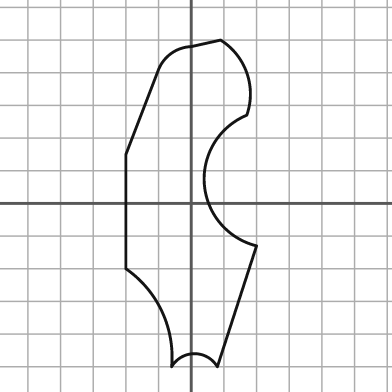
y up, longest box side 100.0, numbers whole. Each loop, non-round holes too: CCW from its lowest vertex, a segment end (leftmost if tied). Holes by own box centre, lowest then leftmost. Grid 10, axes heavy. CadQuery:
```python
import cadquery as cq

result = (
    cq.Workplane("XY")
    .moveTo(-6.0, -50.0)
    .threePointArc((1.0, -46.0), (8.0, -50.0))
    .lineTo(20.0, -13.0)
    .threePointArc((4.0, 6.0), (17.0, 27.0))
    .threePointArc((17.0, 40.0), (9.0, 50.0))
    .lineTo(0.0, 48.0)
    .threePointArc((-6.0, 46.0), (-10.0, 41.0))
    .lineTo(-20.0, 15.0)
    .lineTo(-20.0, -20.0)
    .threePointArc((-9.0, -33.0), (-6.0, -50.0))
    .close()
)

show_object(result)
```